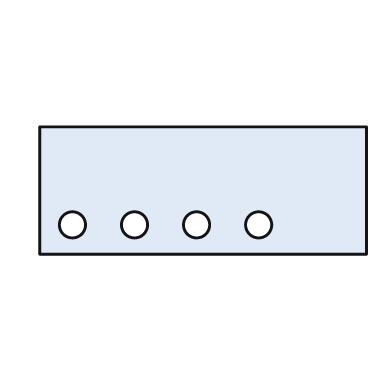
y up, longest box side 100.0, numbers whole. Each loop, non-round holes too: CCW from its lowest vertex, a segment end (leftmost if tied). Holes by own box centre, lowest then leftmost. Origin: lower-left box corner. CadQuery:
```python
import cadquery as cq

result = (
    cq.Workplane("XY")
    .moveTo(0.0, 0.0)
    .lineTo(100.0, 0.0)
    .lineTo(100.0, 39.0)
    .lineTo(0.0, 39.0)
    .close()
    .moveTo(10.0, 9.0)
    .circle(4.0)
    .moveTo(29.0, 9.0)
    .circle(4.0)
    .moveTo(48.0, 9.0)
    .circle(4.0)
    .moveTo(67.0, 9.0)
    .circle(4.0)
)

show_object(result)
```